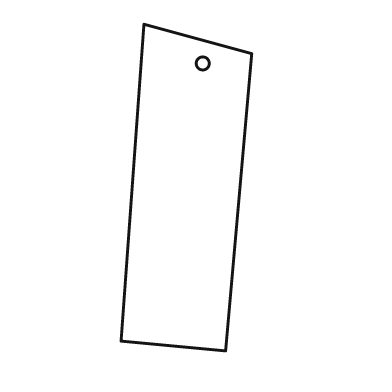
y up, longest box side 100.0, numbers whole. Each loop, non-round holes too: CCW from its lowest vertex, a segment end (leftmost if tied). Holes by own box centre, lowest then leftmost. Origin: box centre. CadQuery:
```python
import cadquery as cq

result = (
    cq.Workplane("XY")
    .moveTo(12.0, -50.0)
    .lineTo(20.0, 41.0)
    .lineTo(-13.0, 50.0)
    .lineTo(-20.0, -47.0)
    .close()
    .moveTo(5.0, 38.0)
    .circle(2.0)
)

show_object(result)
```